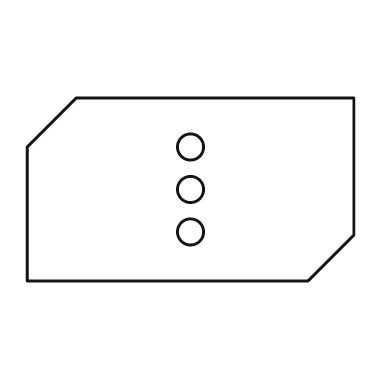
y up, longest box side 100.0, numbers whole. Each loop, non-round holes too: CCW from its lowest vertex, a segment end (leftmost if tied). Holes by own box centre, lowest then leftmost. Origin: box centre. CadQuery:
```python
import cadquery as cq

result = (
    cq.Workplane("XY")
    .moveTo(-50.0, -28.0)
    .lineTo(36.0, -28.0)
    .lineTo(50.0, -14.0)
    .lineTo(50.0, 28.0)
    .lineTo(-35.0, 28.0)
    .lineTo(-50.0, 13.0)
    .close()
    .moveTo(0.0, -13.0)
    .circle(4.0)
    .moveTo(0.0, 0.0)
    .circle(4.0)
    .moveTo(0.0, 13.0)
    .circle(4.0)
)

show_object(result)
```